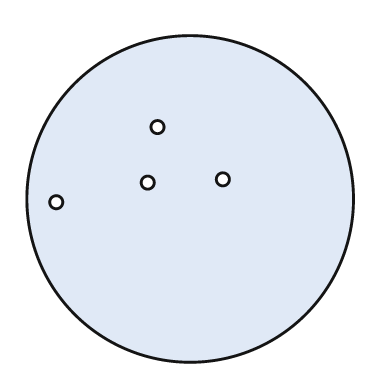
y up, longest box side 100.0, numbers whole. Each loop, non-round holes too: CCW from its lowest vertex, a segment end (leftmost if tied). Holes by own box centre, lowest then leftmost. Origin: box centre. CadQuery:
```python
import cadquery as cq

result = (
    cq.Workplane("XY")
    .moveTo(0.0, 0.0)
    .circle(50.0)
    .moveTo(-41.0, -1.0)
    .circle(2.0)
    .moveTo(-13.0, 5.0)
    .circle(2.0)
    .moveTo(10.0, 6.0)
    .circle(2.0)
    .moveTo(-10.0, 22.0)
    .circle(2.0)
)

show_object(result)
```